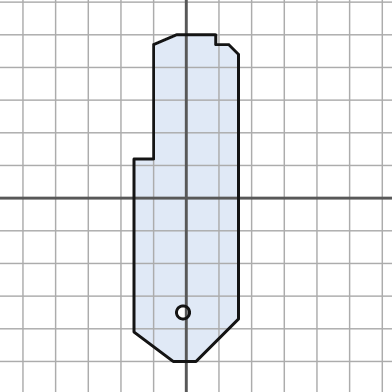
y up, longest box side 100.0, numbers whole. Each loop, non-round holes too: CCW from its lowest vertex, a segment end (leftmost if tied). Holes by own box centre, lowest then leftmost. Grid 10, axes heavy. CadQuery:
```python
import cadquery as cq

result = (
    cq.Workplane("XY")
    .moveTo(-4.0, -50.0)
    .lineTo(3.0, -50.0)
    .lineTo(16.0, -37.0)
    .lineTo(16.0, 44.0)
    .lineTo(13.0, 47.0)
    .lineTo(9.0, 47.0)
    .lineTo(9.0, 50.0)
    .lineTo(-3.0, 50.0)
    .lineTo(-10.0, 47.0)
    .lineTo(-10.0, 12.0)
    .lineTo(-16.0, 12.0)
    .lineTo(-16.0, -41.0)
    .close()
    .moveTo(-1.0, -35.0)
    .circle(2.0)
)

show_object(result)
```